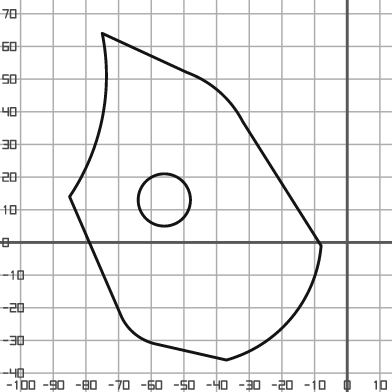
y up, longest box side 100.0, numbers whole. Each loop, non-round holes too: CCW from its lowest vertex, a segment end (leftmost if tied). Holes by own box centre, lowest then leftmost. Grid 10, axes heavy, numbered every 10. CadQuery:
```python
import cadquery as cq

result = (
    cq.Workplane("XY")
    .moveTo(-37.0, -36.0)
    .threePointArc((-17.0, -23.0), (-8.0, -1.0))
    .lineTo(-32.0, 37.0)
    .threePointArc((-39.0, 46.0), (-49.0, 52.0))
    .lineTo(-75.0, 64.0)
    .threePointArc((-75.0, 38.0), (-85.0, 14.0))
    .lineTo(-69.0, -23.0)
    .threePointArc((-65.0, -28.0), (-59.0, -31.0))
    .close()
    .moveTo(-56.0, 13.0)
    .circle(8.0)
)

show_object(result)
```